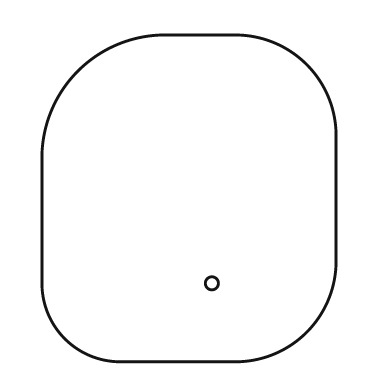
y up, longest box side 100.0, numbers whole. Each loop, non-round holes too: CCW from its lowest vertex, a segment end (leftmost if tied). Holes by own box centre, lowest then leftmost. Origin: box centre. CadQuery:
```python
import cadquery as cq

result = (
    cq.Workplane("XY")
    .moveTo(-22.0, -50.0)
    .lineTo(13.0, -50.0)
    .threePointArc((36.0, -41.0), (45.0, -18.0))
    .lineTo(45.0, 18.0)
    .threePointArc((36.0, 41.0), (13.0, 50.0))
    .lineTo(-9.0, 50.0)
    .threePointArc((-34.0, 39.0), (-45.0, 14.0))
    .lineTo(-45.0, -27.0)
    .threePointArc((-38.0, -43.0), (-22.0, -50.0))
    .close()
    .moveTo(7.0, -26.0)
    .circle(2.0)
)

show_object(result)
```